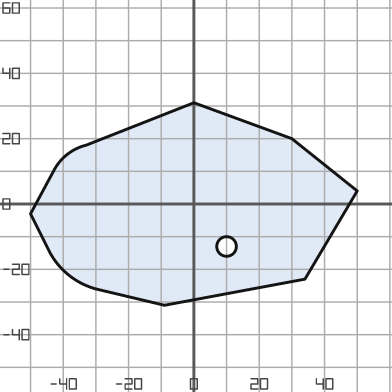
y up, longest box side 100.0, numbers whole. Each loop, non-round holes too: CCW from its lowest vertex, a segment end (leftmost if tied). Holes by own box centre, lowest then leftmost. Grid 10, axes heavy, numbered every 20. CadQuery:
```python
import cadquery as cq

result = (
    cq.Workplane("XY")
    .moveTo(-9.0, -31.0)
    .lineTo(34.0, -23.0)
    .lineTo(50.0, 4.0)
    .lineTo(30.0, 20.0)
    .lineTo(0.0, 31.0)
    .lineTo(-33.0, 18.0)
    .threePointArc((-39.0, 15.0), (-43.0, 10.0))
    .lineTo(-50.0, -3.0)
    .lineTo(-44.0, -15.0)
    .threePointArc((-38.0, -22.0), (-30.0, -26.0))
    .close()
    .moveTo(10.0, -13.0)
    .circle(3.0)
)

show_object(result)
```